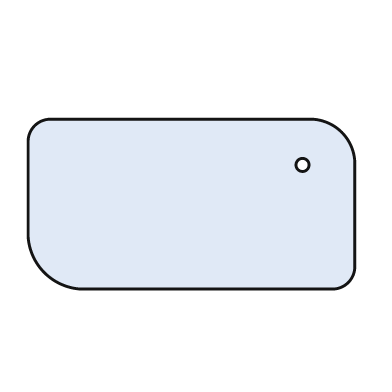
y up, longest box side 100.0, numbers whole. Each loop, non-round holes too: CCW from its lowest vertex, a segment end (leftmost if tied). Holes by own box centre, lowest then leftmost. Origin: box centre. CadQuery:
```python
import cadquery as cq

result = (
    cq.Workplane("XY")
    .moveTo(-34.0, -26.0)
    .lineTo(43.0, -26.0)
    .threePointArc((48.0, -24.0), (50.0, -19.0))
    .lineTo(50.0, 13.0)
    .threePointArc((46.0, 22.0), (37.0, 26.0))
    .lineTo(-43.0, 26.0)
    .threePointArc((-48.0, 24.0), (-50.0, 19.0))
    .lineTo(-50.0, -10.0)
    .threePointArc((-45.0, -21.0), (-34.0, -26.0))
    .close()
    .moveTo(34.0, 12.0)
    .circle(2.0)
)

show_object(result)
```